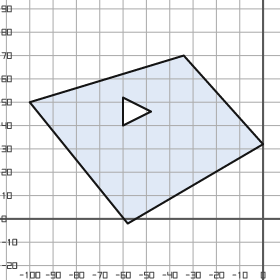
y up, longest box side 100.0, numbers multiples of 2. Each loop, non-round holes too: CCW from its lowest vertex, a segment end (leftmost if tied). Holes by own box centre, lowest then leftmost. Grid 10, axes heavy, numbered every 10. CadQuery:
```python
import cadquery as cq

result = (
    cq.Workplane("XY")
    .moveTo(-58.0, -2.0)
    .lineTo(0.0, 32.0)
    .lineTo(-34.0, 70.0)
    .lineTo(-100.0, 50.0)
    .close()
    .moveTo(-60.0, 40.0)
    .lineTo(-48.0, 46.0)
    .lineTo(-60.0, 52.0)
    .close()
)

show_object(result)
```